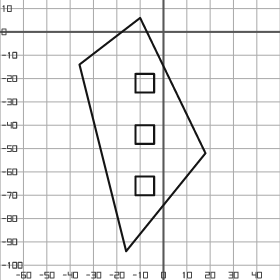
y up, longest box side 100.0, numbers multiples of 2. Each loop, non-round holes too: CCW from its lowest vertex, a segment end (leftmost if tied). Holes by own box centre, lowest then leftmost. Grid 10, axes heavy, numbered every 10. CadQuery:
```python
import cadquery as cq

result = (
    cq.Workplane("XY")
    .moveTo(-16.0, -94.0)
    .lineTo(18.0, -52.0)
    .lineTo(-10.0, 6.0)
    .lineTo(-36.0, -14.0)
    .close()
    .moveTo(-12.0, -70.0)
    .lineTo(-4.0, -70.0)
    .lineTo(-4.0, -62.0)
    .lineTo(-12.0, -62.0)
    .close()
    .moveTo(-12.0, -48.0)
    .lineTo(-4.0, -48.0)
    .lineTo(-4.0, -40.0)
    .lineTo(-12.0, -40.0)
    .close()
    .moveTo(-12.0, -26.0)
    .lineTo(-4.0, -26.0)
    .lineTo(-4.0, -18.0)
    .lineTo(-12.0, -18.0)
    .close()
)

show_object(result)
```